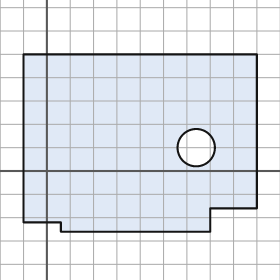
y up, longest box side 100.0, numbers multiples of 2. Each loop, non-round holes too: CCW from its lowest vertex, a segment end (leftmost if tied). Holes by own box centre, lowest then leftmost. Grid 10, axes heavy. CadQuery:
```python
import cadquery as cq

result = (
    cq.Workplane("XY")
    .moveTo(6.0, -26.0)
    .lineTo(70.0, -26.0)
    .lineTo(70.0, -16.0)
    .lineTo(90.0, -16.0)
    .lineTo(90.0, 50.0)
    .lineTo(-10.0, 50.0)
    .lineTo(-10.0, -22.0)
    .lineTo(6.0, -22.0)
    .close()
    .moveTo(64.0, 10.0)
    .circle(8.0)
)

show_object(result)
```